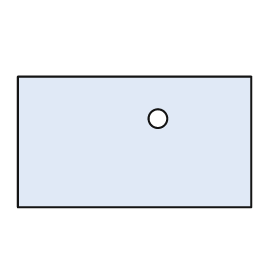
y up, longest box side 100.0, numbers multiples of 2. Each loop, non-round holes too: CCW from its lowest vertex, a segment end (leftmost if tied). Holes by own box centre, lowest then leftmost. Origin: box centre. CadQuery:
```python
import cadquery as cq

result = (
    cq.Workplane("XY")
    .moveTo(-50.0, -28.0)
    .lineTo(50.0, -28.0)
    .lineTo(50.0, 28.0)
    .lineTo(-50.0, 28.0)
    .close()
    .moveTo(10.0, 10.0)
    .circle(4.0)
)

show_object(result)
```